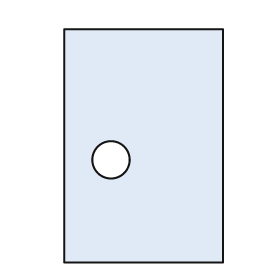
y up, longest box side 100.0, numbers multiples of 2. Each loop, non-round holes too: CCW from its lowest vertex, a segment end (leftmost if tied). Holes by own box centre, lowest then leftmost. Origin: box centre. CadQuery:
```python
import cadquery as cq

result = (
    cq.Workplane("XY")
    .moveTo(-34.0, -50.0)
    .lineTo(34.0, -50.0)
    .lineTo(34.0, 50.0)
    .lineTo(-34.0, 50.0)
    .close()
    .moveTo(-14.0, -6.0)
    .circle(8.0)
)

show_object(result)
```